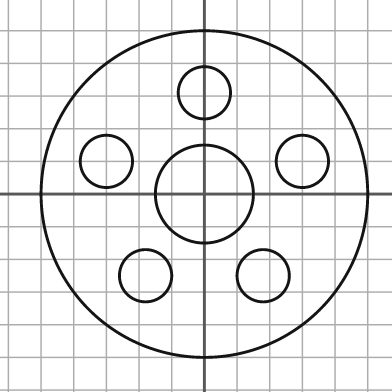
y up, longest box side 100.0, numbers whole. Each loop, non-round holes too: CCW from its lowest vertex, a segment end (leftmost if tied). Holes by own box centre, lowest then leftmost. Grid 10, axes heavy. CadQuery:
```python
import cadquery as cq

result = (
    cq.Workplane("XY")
    .moveTo(0.0, 0.0)
    .circle(50.0)
    .moveTo(-18.0, -25.0)
    .circle(8.0)
    .moveTo(18.0, -25.0)
    .circle(8.0)
    .moveTo(0.0, 0.0)
    .circle(15.0)
    .moveTo(-30.0, 10.0)
    .circle(8.0)
    .moveTo(30.0, 10.0)
    .circle(8.0)
    .moveTo(0.0, 31.0)
    .circle(8.0)
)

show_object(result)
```